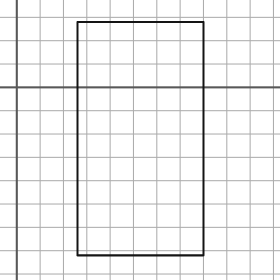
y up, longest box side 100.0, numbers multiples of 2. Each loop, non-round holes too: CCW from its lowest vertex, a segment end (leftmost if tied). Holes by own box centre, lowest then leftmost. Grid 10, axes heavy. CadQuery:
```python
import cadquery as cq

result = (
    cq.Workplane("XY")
    .moveTo(26.0, -72.0)
    .lineTo(80.0, -72.0)
    .lineTo(80.0, 28.0)
    .lineTo(26.0, 28.0)
    .close()
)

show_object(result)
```